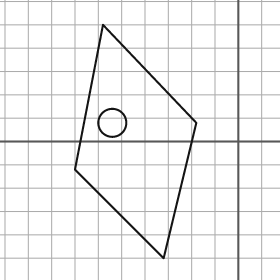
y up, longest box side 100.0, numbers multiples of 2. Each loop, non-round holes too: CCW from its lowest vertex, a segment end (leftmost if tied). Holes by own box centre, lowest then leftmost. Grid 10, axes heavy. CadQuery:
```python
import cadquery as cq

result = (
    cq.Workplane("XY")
    .moveTo(-32.0, -50.0)
    .lineTo(-18.0, 8.0)
    .lineTo(-58.0, 50.0)
    .lineTo(-70.0, -12.0)
    .close()
    .moveTo(-54.0, 8.0)
    .circle(6.0)
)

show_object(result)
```